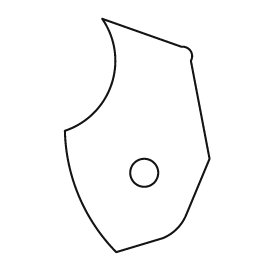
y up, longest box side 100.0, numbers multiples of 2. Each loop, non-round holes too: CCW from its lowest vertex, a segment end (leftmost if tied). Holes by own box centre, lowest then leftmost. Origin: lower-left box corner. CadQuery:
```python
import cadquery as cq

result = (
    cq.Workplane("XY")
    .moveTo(22.0, 0.0)
    .lineTo(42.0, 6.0)
    .threePointArc((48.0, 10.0), (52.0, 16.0))
    .lineTo(62.0, 40.0)
    .lineTo(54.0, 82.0)
    .threePointArc((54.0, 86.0), (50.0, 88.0))
    .lineTo(16.0, 100.0)
    .threePointArc((20.0, 72.0), (0.0, 52.0))
    .threePointArc((6.0, 24.0), (22.0, 0.0))
    .close()
    .moveTo(34.0, 34.0)
    .circle(6.0)
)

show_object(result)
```